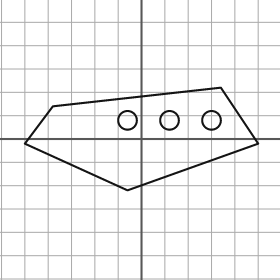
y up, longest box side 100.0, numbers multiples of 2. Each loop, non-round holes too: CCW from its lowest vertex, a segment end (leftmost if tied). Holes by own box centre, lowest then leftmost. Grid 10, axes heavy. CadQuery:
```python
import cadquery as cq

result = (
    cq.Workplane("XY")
    .moveTo(-6.0, -22.0)
    .lineTo(50.0, -2.0)
    .lineTo(34.0, 22.0)
    .lineTo(-38.0, 14.0)
    .lineTo(-50.0, -2.0)
    .close()
    .moveTo(-6.0, 8.0)
    .circle(4.0)
    .moveTo(12.0, 8.0)
    .circle(4.0)
    .moveTo(30.0, 8.0)
    .circle(4.0)
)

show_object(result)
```